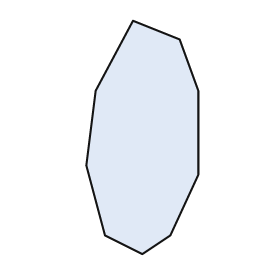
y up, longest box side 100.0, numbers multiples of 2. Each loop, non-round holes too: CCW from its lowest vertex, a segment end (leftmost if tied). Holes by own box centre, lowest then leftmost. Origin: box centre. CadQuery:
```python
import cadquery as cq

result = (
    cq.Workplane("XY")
    .moveTo(0.0, -50.0)
    .lineTo(12.0, -42.0)
    .lineTo(24.0, -16.0)
    .lineTo(24.0, 20.0)
    .lineTo(16.0, 42.0)
    .lineTo(-4.0, 50.0)
    .lineTo(-20.0, 20.0)
    .lineTo(-24.0, -12.0)
    .lineTo(-16.0, -42.0)
    .close()
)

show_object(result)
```